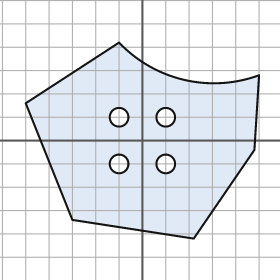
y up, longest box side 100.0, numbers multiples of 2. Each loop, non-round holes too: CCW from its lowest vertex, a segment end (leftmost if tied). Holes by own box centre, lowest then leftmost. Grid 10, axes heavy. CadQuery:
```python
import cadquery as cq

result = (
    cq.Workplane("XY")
    .moveTo(22.0, -42.0)
    .lineTo(48.0, -4.0)
    .lineTo(50.0, 28.0)
    .threePointArc((18.0, 26.0), (-10.0, 42.0))
    .lineTo(-50.0, 16.0)
    .lineTo(-30.0, -34.0)
    .close()
    .moveTo(-10.0, -10.0)
    .circle(4.0)
    .moveTo(10.0, -10.0)
    .circle(4.0)
    .moveTo(-10.0, 10.0)
    .circle(4.0)
    .moveTo(10.0, 10.0)
    .circle(4.0)
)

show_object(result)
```